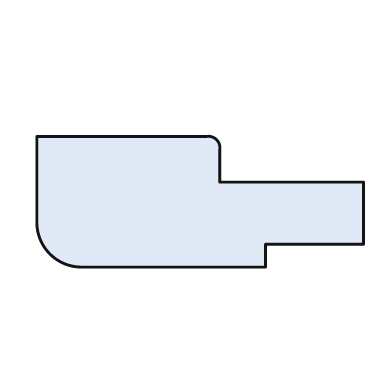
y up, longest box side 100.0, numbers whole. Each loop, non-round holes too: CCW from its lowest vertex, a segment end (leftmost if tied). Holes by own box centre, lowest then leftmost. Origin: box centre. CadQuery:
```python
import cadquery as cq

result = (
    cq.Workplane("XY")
    .moveTo(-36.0, -20.0)
    .lineTo(20.0, -20.0)
    .lineTo(20.0, -13.0)
    .lineTo(50.0, -13.0)
    .lineTo(50.0, 6.0)
    .lineTo(6.0, 6.0)
    .lineTo(6.0, 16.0)
    .threePointArc((5.0, 19.0), (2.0, 20.0))
    .lineTo(-50.0, 20.0)
    .lineTo(-50.0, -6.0)
    .threePointArc((-46.0, -16.0), (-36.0, -20.0))
    .close()
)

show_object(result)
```